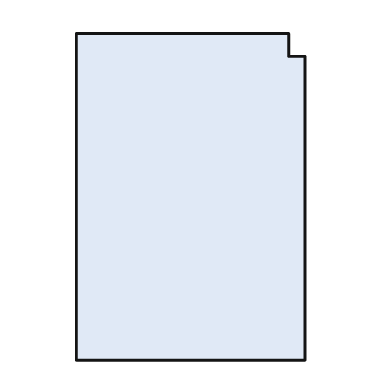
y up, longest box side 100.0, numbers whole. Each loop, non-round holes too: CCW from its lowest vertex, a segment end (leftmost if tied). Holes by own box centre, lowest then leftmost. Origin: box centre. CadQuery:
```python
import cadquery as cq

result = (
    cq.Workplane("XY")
    .moveTo(-35.0, -50.0)
    .lineTo(35.0, -50.0)
    .lineTo(35.0, 43.0)
    .lineTo(30.0, 43.0)
    .lineTo(30.0, 50.0)
    .lineTo(-35.0, 50.0)
    .close()
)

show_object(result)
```